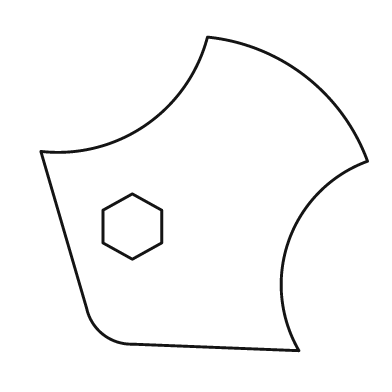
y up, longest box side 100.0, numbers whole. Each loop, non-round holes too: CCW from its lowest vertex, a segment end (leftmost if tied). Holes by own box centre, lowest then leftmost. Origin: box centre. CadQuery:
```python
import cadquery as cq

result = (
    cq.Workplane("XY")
    .moveTo(29.0, -48.0)
    .threePointArc((26.0, -14.0), (50.0, 10.0))
    .threePointArc((31.0, 36.0), (1.0, 48.0))
    .threePointArc((-18.0, 21.0), (-50.0, 13.0))
    .lineTo(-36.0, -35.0)
    .threePointArc((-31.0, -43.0), (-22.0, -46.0))
    .close()
    .moveTo(-22.0, -20.0)
    .lineTo(-13.0, -15.0)
    .lineTo(-13.0, -5.0)
    .lineTo(-22.0, 0.0)
    .lineTo(-31.0, -5.0)
    .lineTo(-31.0, -15.0)
    .close()
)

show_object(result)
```